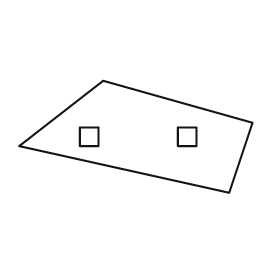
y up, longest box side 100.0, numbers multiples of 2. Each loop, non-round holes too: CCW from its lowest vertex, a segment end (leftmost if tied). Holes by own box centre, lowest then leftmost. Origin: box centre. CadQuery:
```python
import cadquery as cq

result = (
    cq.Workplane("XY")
    .moveTo(40.0, -24.0)
    .lineTo(50.0, 6.0)
    .lineTo(-14.0, 24.0)
    .lineTo(-50.0, -4.0)
    .close()
    .moveTo(-24.0, -4.0)
    .lineTo(-16.0, -4.0)
    .lineTo(-16.0, 4.0)
    .lineTo(-24.0, 4.0)
    .close()
    .moveTo(18.0, -4.0)
    .lineTo(26.0, -4.0)
    .lineTo(26.0, 4.0)
    .lineTo(18.0, 4.0)
    .close()
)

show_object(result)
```